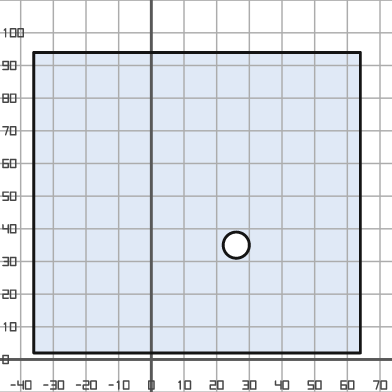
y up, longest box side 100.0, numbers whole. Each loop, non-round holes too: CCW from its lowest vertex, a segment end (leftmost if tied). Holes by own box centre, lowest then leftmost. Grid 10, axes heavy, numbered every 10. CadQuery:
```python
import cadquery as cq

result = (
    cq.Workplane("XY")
    .moveTo(-36.0, 2.0)
    .lineTo(64.0, 2.0)
    .lineTo(64.0, 94.0)
    .lineTo(-36.0, 94.0)
    .close()
    .moveTo(26.0, 35.0)
    .circle(4.0)
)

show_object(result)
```